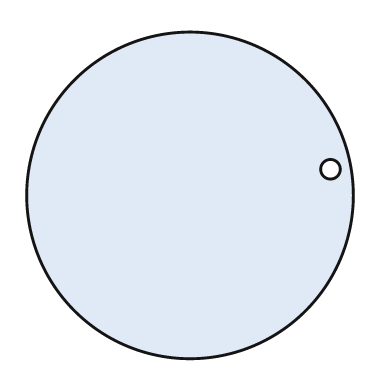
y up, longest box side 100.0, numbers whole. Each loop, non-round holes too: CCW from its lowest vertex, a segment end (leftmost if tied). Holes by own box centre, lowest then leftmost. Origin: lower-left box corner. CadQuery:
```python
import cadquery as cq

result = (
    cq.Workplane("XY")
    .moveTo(50.0, 50.0)
    .circle(50.0)
    .moveTo(93.0, 58.0)
    .circle(3.0)
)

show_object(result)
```